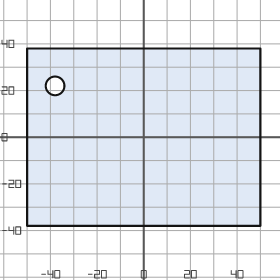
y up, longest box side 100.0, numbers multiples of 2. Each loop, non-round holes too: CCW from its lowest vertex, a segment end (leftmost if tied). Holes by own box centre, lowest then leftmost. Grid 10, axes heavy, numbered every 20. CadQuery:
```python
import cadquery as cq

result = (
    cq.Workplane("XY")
    .moveTo(-50.0, -38.0)
    .lineTo(50.0, -38.0)
    .lineTo(50.0, 38.0)
    .lineTo(-50.0, 38.0)
    .close()
    .moveTo(-38.0, 22.0)
    .circle(4.0)
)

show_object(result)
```